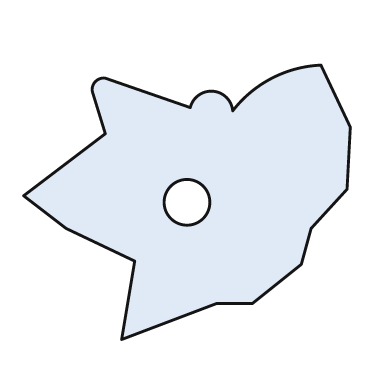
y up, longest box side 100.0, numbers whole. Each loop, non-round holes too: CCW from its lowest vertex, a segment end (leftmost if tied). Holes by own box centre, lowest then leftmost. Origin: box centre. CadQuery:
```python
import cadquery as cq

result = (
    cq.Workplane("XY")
    .moveTo(-20.0, -42.0)
    .lineTo(9.0, -31.0)
    .lineTo(20.0, -31.0)
    .lineTo(35.0, -19.0)
    .lineTo(38.0, -8.0)
    .lineTo(49.0, 4.0)
    .lineTo(50.0, 23.0)
    .lineTo(41.0, 42.0)
    .threePointArc((26.0, 38.0), (14.0, 28.0))
    .threePointArc((8.0, 34.0), (1.0, 29.0))
    .lineTo(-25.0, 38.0)
    .threePointArc((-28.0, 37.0), (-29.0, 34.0))
    .lineTo(-25.0, 21.0)
    .lineTo(-50.0, 2.0)
    .lineTo(-37.0, -8.0)
    .lineTo(-16.0, -18.0)
    .close()
    .moveTo(0.0, 0.0)
    .circle(7.0)
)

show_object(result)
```